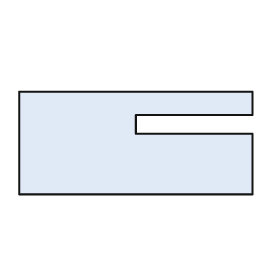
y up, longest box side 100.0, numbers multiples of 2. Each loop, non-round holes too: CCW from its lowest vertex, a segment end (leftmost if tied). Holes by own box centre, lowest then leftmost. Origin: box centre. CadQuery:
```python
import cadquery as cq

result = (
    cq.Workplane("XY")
    .moveTo(-50.0, -22.0)
    .lineTo(50.0, -22.0)
    .lineTo(50.0, 4.0)
    .lineTo(0.0, 4.0)
    .lineTo(0.0, 12.0)
    .lineTo(50.0, 12.0)
    .lineTo(50.0, 22.0)
    .lineTo(-50.0, 22.0)
    .close()
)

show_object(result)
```